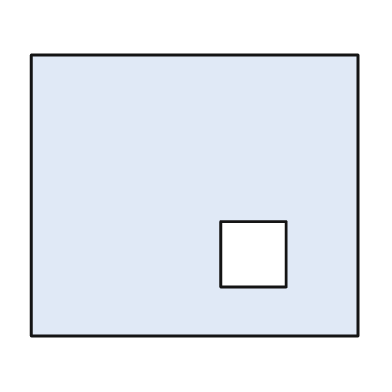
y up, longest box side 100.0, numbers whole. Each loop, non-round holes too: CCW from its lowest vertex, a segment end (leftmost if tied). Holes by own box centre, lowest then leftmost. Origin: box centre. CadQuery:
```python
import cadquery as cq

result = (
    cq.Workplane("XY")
    .moveTo(-50.0, -43.0)
    .lineTo(50.0, -43.0)
    .lineTo(50.0, 43.0)
    .lineTo(-50.0, 43.0)
    .close()
    .moveTo(8.0, -28.0)
    .lineTo(28.0, -28.0)
    .lineTo(28.0, -8.0)
    .lineTo(8.0, -8.0)
    .close()
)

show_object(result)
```